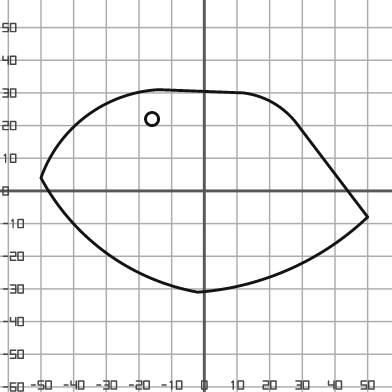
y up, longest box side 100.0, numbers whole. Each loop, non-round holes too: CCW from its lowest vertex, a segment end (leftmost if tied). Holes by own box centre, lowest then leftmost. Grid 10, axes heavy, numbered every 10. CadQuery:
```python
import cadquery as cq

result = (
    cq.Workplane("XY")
    .moveTo(-2.0, -31.0)
    .threePointArc((26.0, -24.0), (50.0, -8.0))
    .lineTo(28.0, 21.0)
    .threePointArc((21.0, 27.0), (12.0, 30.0))
    .lineTo(-14.0, 31.0)
    .threePointArc((-36.0, 23.0), (-50.0, 4.0))
    .threePointArc((-30.0, -19.0), (-2.0, -31.0))
    .close()
    .moveTo(-16.0, 22.0)
    .circle(2.0)
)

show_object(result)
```